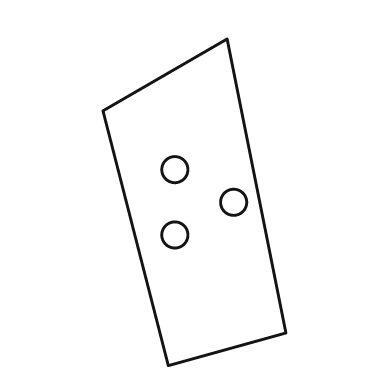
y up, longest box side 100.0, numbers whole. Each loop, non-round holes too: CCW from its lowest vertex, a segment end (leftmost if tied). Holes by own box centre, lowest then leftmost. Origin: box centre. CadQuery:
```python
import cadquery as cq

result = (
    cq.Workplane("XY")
    .moveTo(-8.0, -50.0)
    .lineTo(28.0, -40.0)
    .lineTo(10.0, 50.0)
    .lineTo(-28.0, 28.0)
    .close()
    .moveTo(-6.0, -10.0)
    .circle(4.0)
    .moveTo(12.0, 0.0)
    .circle(4.0)
    .moveTo(-6.0, 10.0)
    .circle(4.0)
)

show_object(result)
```